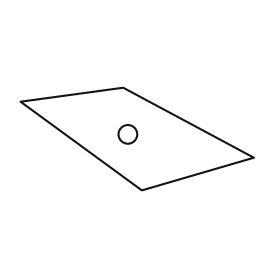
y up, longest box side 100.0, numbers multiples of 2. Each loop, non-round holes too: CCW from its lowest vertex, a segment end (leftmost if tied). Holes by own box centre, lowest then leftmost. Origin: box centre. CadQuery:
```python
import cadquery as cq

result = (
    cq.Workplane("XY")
    .moveTo(2.0, -22.0)
    .lineTo(50.0, -8.0)
    .lineTo(-6.0, 22.0)
    .lineTo(-50.0, 16.0)
    .close()
    .moveTo(-4.0, 2.0)
    .circle(4.0)
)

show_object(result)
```